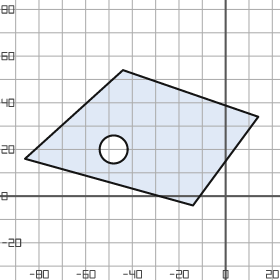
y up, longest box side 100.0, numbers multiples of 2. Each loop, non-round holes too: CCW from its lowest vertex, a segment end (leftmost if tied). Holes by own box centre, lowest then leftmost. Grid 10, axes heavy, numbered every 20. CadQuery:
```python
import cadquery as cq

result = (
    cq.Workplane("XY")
    .moveTo(-14.0, -4.0)
    .lineTo(14.0, 34.0)
    .lineTo(-44.0, 54.0)
    .lineTo(-86.0, 16.0)
    .close()
    .moveTo(-48.0, 20.0)
    .circle(6.0)
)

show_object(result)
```